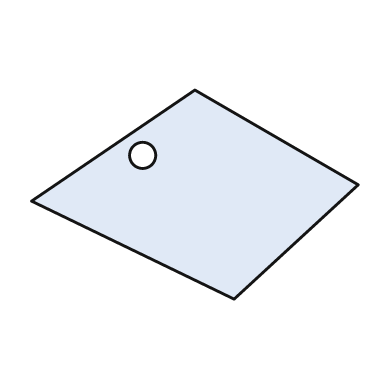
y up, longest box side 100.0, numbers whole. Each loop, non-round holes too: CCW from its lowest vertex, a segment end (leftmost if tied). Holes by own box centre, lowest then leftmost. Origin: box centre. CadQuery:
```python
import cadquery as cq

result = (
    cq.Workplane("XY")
    .moveTo(12.0, -32.0)
    .lineTo(50.0, 3.0)
    .lineTo(0.0, 32.0)
    .lineTo(-50.0, -2.0)
    .close()
    .moveTo(-16.0, 12.0)
    .circle(4.0)
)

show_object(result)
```